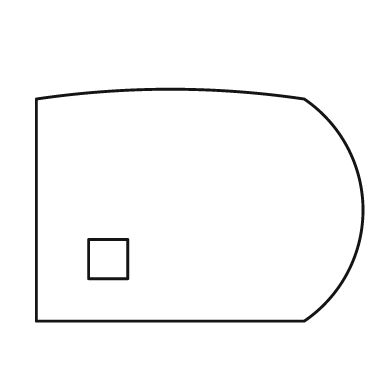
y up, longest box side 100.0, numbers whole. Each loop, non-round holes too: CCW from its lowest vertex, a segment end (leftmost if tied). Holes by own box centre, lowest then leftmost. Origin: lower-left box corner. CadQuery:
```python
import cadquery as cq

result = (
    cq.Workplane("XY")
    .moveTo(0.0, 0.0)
    .lineTo(82.0, 0.0)
    .threePointArc((100.0, 34.0), (82.0, 68.0))
    .threePointArc((41.0, 71.0), (0.0, 68.0))
    .close()
    .moveTo(16.0, 13.0)
    .lineTo(28.0, 13.0)
    .lineTo(28.0, 25.0)
    .lineTo(16.0, 25.0)
    .close()
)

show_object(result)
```